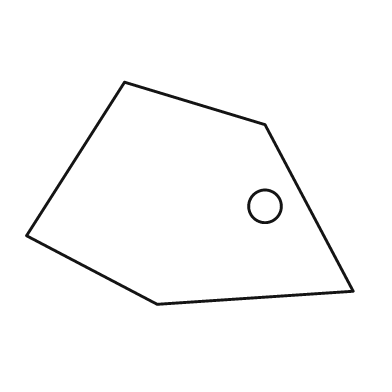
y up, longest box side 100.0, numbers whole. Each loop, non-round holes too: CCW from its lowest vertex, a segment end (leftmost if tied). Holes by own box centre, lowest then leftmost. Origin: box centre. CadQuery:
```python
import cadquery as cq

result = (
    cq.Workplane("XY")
    .moveTo(-10.0, -34.0)
    .lineTo(50.0, -30.0)
    .lineTo(23.0, 21.0)
    .lineTo(-20.0, 34.0)
    .lineTo(-50.0, -13.0)
    .close()
    .moveTo(23.0, -4.0)
    .circle(5.0)
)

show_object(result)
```